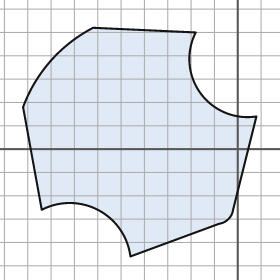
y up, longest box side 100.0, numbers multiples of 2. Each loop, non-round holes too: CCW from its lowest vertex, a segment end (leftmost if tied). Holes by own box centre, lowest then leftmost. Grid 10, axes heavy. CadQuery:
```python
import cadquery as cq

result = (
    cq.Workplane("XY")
    .moveTo(-46.0, -46.0)
    .lineTo(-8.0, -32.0)
    .threePointArc((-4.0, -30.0), (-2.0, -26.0))
    .lineTo(8.0, 14.0)
    .threePointArc((-16.0, 24.0), (-18.0, 50.0))
    .lineTo(-62.0, 52.0)
    .threePointArc((-80.0, 38.0), (-92.0, 18.0))
    .lineTo(-84.0, -26.0)
    .threePointArc((-60.0, -26.0), (-46.0, -46.0))
    .close()
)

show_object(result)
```